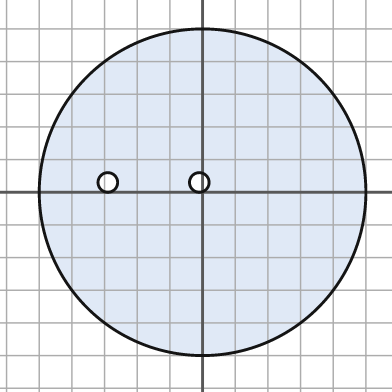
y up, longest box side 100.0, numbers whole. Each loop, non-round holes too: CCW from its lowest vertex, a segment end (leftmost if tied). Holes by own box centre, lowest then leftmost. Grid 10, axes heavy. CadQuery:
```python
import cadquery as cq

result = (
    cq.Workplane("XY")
    .moveTo(0.0, 0.0)
    .circle(50.0)
    .moveTo(-29.0, 3.0)
    .circle(3.0)
    .moveTo(-1.0, 3.0)
    .circle(3.0)
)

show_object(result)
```